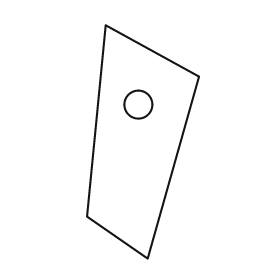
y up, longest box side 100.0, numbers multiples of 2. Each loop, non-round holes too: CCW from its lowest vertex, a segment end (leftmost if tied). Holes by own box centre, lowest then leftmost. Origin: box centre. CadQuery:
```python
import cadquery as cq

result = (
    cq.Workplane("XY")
    .moveTo(2.0, -50.0)
    .lineTo(24.0, 28.0)
    .lineTo(-16.0, 50.0)
    .lineTo(-24.0, -32.0)
    .close()
    .moveTo(-2.0, 16.0)
    .circle(6.0)
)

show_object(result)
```